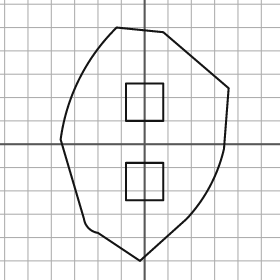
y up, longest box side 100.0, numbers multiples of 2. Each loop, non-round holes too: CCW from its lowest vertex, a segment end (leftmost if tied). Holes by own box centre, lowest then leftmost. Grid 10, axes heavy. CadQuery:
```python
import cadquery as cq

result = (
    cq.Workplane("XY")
    .moveTo(-2.0, -50.0)
    .lineTo(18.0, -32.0)
    .threePointArc((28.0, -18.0), (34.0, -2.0))
    .lineTo(36.0, 24.0)
    .lineTo(8.0, 48.0)
    .lineTo(-12.0, 50.0)
    .threePointArc((-28.0, 28.0), (-36.0, 2.0))
    .lineTo(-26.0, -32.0)
    .threePointArc((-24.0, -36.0), (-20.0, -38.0))
    .close()
    .moveTo(-8.0, -24.0)
    .lineTo(8.0, -24.0)
    .lineTo(8.0, -8.0)
    .lineTo(-8.0, -8.0)
    .close()
    .moveTo(-8.0, 10.0)
    .lineTo(8.0, 10.0)
    .lineTo(8.0, 26.0)
    .lineTo(-8.0, 26.0)
    .close()
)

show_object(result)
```